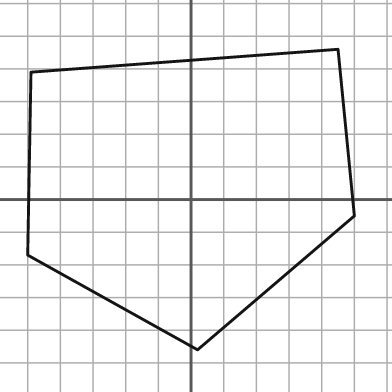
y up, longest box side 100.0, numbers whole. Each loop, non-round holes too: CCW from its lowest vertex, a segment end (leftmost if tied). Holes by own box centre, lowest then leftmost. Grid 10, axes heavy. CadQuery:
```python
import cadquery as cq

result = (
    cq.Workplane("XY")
    .moveTo(2.0, -46.0)
    .lineTo(50.0, -5.0)
    .lineTo(45.0, 46.0)
    .lineTo(-49.0, 39.0)
    .lineTo(-50.0, -17.0)
    .close()
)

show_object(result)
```